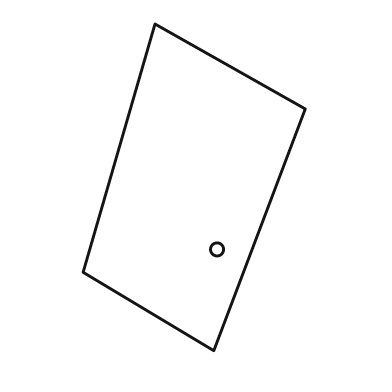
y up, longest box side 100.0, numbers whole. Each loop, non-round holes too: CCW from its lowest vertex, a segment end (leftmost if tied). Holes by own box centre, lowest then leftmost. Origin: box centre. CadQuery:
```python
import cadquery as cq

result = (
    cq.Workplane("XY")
    .moveTo(6.0, -50.0)
    .lineTo(34.0, 24.0)
    .lineTo(-12.0, 50.0)
    .lineTo(-34.0, -26.0)
    .close()
    .moveTo(7.0, -19.0)
    .circle(2.0)
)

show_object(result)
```